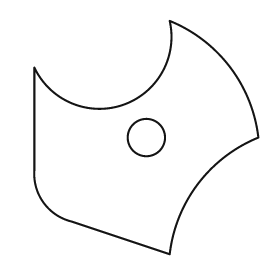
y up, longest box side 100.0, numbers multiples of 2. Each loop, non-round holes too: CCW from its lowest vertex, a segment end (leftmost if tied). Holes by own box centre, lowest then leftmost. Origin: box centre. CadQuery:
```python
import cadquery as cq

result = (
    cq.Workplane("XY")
    .moveTo(10.0, -50.0)
    .threePointArc((22.0, -20.0), (48.0, 0.0))
    .threePointArc((36.0, 30.0), (10.0, 50.0))
    .threePointArc((-10.0, 14.0), (-48.0, 30.0))
    .lineTo(-48.0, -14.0)
    .threePointArc((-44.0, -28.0), (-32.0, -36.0))
    .close()
    .moveTo(0.0, 0.0)
    .circle(8.0)
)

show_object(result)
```